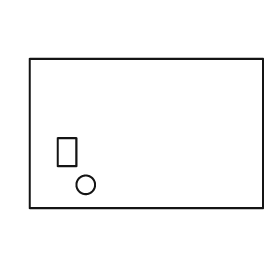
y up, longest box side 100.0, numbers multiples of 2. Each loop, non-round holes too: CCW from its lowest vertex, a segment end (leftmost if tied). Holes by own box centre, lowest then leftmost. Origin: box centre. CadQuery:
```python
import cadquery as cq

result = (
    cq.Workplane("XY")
    .moveTo(-50.0, -32.0)
    .lineTo(50.0, -32.0)
    .lineTo(50.0, 32.0)
    .lineTo(-50.0, 32.0)
    .close()
    .moveTo(-26.0, -22.0)
    .circle(4.0)
    .moveTo(-38.0, -14.0)
    .lineTo(-30.0, -14.0)
    .lineTo(-30.0, -2.0)
    .lineTo(-38.0, -2.0)
    .close()
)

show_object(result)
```